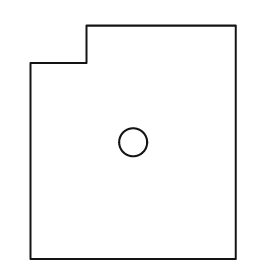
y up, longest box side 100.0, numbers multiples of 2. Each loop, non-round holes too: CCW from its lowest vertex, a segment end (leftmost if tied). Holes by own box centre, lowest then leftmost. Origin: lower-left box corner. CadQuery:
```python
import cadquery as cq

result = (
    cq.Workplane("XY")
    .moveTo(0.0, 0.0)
    .lineTo(88.0, 0.0)
    .lineTo(88.0, 100.0)
    .lineTo(24.0, 100.0)
    .lineTo(24.0, 84.0)
    .lineTo(0.0, 84.0)
    .close()
    .moveTo(44.0, 50.0)
    .circle(6.0)
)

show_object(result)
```